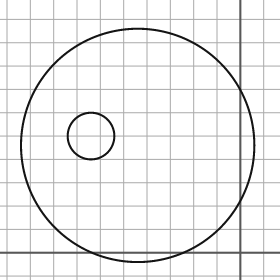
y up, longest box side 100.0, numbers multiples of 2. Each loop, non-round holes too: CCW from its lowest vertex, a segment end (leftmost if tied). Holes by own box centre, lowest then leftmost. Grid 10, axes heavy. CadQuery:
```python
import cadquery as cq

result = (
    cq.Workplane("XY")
    .moveTo(-44.0, 46.0)
    .circle(50.0)
    .moveTo(-64.0, 50.0)
    .circle(10.0)
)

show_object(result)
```